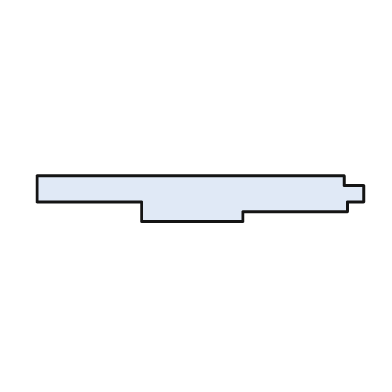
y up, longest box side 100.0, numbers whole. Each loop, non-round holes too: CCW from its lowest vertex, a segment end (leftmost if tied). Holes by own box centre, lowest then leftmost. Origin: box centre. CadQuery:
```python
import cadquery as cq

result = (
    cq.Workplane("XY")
    .moveTo(-18.0, -7.0)
    .lineTo(13.0, -7.0)
    .lineTo(13.0, -4.0)
    .lineTo(45.0, -4.0)
    .lineTo(45.0, -1.0)
    .lineTo(50.0, -1.0)
    .lineTo(50.0, 4.0)
    .lineTo(44.0, 4.0)
    .lineTo(44.0, 7.0)
    .lineTo(-50.0, 7.0)
    .lineTo(-50.0, -1.0)
    .lineTo(-18.0, -1.0)
    .close()
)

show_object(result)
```